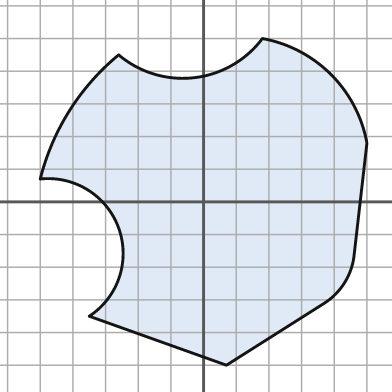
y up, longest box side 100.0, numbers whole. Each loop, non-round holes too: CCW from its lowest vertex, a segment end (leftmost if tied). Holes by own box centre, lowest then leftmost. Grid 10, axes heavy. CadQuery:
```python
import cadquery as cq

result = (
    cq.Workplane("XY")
    .moveTo(7.0, -50.0)
    .lineTo(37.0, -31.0)
    .threePointArc((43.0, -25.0), (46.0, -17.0))
    .lineTo(50.0, 18.0)
    .threePointArc((39.0, 39.0), (18.0, 50.0))
    .threePointArc((-3.0, 38.0), (-26.0, 45.0))
    .threePointArc((-41.0, 28.0), (-50.0, 7.0))
    .threePointArc((-26.0, -8.0), (-35.0, -35.0))
    .close()
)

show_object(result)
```